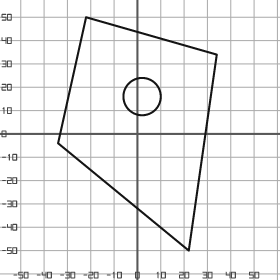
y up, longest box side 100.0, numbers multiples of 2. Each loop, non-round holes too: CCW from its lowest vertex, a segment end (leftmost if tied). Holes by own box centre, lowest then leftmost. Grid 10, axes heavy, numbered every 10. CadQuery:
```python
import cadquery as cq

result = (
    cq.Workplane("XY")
    .moveTo(22.0, -50.0)
    .lineTo(34.0, 34.0)
    .lineTo(-22.0, 50.0)
    .lineTo(-34.0, -4.0)
    .close()
    .moveTo(2.0, 16.0)
    .circle(8.0)
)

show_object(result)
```